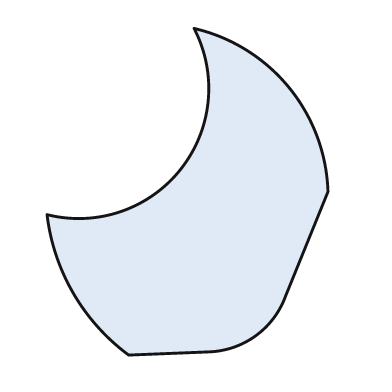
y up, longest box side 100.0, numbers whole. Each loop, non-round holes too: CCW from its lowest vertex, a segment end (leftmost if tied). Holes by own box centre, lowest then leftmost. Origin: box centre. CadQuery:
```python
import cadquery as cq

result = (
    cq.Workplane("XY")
    .moveTo(-18.0, -50.0)
    .lineTo(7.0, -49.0)
    .threePointArc((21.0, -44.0), (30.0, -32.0))
    .lineTo(43.0, 0.0)
    .threePointArc((31.0, 32.0), (2.0, 50.0))
    .threePointArc((-2.0, 7.0), (-43.0, -7.0))
    .threePointArc((-35.0, -31.0), (-18.0, -50.0))
    .close()
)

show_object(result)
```